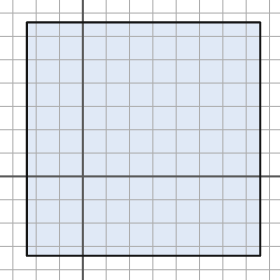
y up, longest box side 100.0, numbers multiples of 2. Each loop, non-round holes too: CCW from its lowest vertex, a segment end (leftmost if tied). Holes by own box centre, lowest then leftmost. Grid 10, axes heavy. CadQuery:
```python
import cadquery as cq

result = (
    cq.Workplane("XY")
    .moveTo(-24.0, -34.0)
    .lineTo(76.0, -34.0)
    .lineTo(76.0, 66.0)
    .lineTo(-24.0, 66.0)
    .close()
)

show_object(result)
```